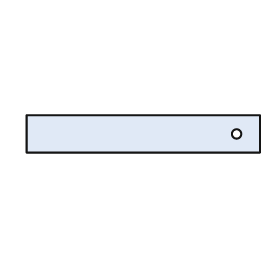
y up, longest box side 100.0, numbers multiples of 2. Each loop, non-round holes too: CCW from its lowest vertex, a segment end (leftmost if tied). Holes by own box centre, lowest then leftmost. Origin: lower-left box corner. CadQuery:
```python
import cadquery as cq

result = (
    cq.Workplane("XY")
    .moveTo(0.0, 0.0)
    .lineTo(100.0, 0.0)
    .lineTo(100.0, 16.0)
    .lineTo(0.0, 16.0)
    .close()
    .moveTo(90.0, 8.0)
    .circle(2.0)
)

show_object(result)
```